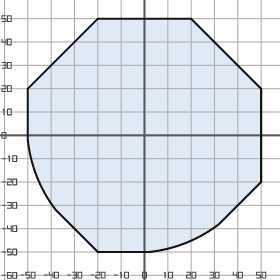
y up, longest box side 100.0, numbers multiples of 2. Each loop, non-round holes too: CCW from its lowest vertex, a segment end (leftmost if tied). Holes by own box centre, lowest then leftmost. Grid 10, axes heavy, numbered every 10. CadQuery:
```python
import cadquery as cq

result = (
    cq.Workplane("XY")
    .moveTo(-20.0, -50.0)
    .lineTo(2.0, -50.0)
    .threePointArc((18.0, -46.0), (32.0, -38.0))
    .lineTo(50.0, -20.0)
    .lineTo(50.0, 20.0)
    .lineTo(20.0, 50.0)
    .lineTo(-20.0, 50.0)
    .lineTo(-50.0, 20.0)
    .lineTo(-50.0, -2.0)
    .threePointArc((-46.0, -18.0), (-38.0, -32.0))
    .close()
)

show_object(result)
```